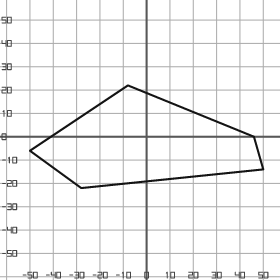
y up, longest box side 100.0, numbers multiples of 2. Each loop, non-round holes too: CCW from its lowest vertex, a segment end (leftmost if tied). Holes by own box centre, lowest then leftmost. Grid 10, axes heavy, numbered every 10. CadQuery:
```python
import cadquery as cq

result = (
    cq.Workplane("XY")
    .moveTo(-28.0, -22.0)
    .lineTo(50.0, -14.0)
    .lineTo(46.0, 0.0)
    .lineTo(-8.0, 22.0)
    .lineTo(-50.0, -6.0)
    .close()
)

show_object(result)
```